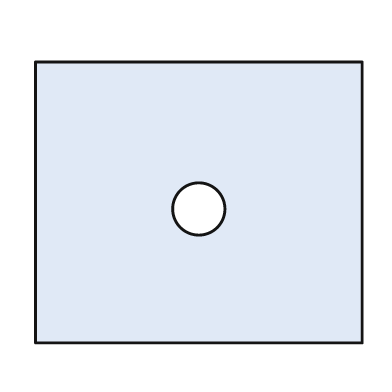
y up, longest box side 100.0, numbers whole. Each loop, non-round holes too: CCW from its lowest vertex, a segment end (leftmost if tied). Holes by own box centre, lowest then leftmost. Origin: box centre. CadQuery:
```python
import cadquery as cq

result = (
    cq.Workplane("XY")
    .moveTo(-50.0, -43.0)
    .lineTo(50.0, -43.0)
    .lineTo(50.0, 43.0)
    .lineTo(-50.0, 43.0)
    .close()
    .moveTo(0.0, -2.0)
    .circle(8.0)
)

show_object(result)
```